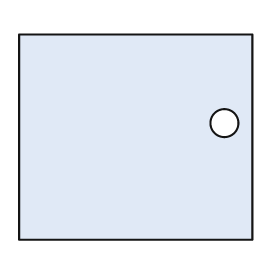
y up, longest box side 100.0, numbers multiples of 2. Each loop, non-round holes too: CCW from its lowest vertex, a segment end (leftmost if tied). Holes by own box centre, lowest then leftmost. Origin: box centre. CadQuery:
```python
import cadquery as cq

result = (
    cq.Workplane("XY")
    .moveTo(-50.0, -44.0)
    .lineTo(50.0, -44.0)
    .lineTo(50.0, 44.0)
    .lineTo(-50.0, 44.0)
    .close()
    .moveTo(38.0, 6.0)
    .circle(6.0)
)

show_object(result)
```